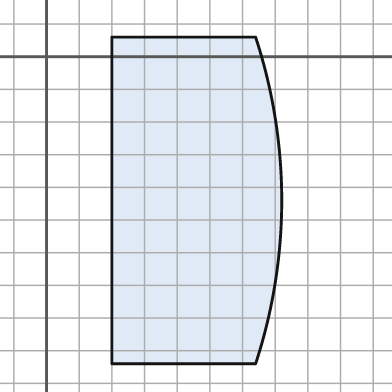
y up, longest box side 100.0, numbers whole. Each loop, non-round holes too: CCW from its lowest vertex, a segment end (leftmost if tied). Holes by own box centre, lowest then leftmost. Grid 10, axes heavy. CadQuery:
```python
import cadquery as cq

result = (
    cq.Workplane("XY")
    .moveTo(20.0, -94.0)
    .lineTo(64.0, -94.0)
    .threePointArc((72.0, -44.0), (64.0, 6.0))
    .lineTo(20.0, 6.0)
    .close()
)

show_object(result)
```